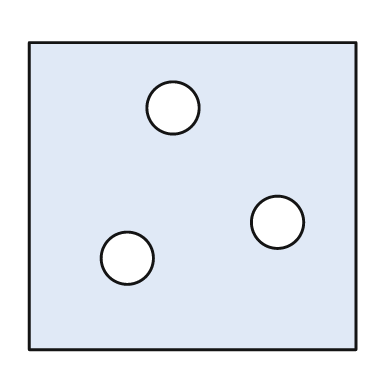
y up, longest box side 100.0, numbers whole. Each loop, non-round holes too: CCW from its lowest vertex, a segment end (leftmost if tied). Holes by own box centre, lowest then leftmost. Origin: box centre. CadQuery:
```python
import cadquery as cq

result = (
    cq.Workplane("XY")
    .moveTo(-50.0, -47.0)
    .lineTo(50.0, -47.0)
    .lineTo(50.0, 47.0)
    .lineTo(-50.0, 47.0)
    .close()
    .moveTo(-20.0, -19.0)
    .circle(8.0)
    .moveTo(26.0, -8.0)
    .circle(8.0)
    .moveTo(-6.0, 27.0)
    .circle(8.0)
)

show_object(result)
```